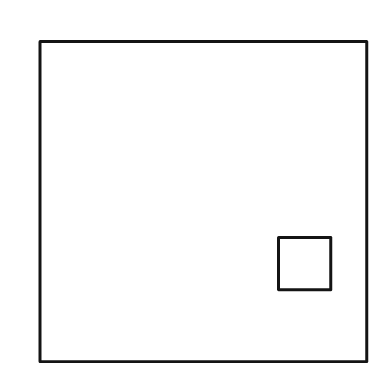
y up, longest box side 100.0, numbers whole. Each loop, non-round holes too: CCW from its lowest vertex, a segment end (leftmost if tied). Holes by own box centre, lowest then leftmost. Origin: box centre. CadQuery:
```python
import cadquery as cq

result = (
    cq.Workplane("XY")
    .moveTo(-50.0, -49.0)
    .lineTo(50.0, -49.0)
    .lineTo(50.0, 49.0)
    .lineTo(-50.0, 49.0)
    .close()
    .moveTo(23.0, -27.0)
    .lineTo(39.0, -27.0)
    .lineTo(39.0, -11.0)
    .lineTo(23.0, -11.0)
    .close()
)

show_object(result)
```